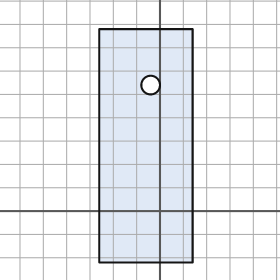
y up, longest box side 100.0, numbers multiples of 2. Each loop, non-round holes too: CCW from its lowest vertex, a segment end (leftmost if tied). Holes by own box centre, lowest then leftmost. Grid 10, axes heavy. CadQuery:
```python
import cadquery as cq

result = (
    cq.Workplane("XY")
    .moveTo(-26.0, -22.0)
    .lineTo(14.0, -22.0)
    .lineTo(14.0, 78.0)
    .lineTo(-26.0, 78.0)
    .close()
    .moveTo(-4.0, 54.0)
    .circle(4.0)
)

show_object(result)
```